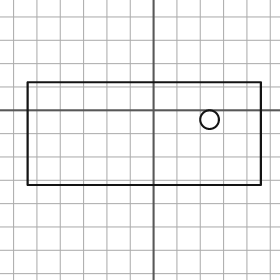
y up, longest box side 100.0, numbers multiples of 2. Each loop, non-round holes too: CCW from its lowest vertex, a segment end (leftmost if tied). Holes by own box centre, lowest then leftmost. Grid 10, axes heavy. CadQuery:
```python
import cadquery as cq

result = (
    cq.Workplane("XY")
    .moveTo(-54.0, -32.0)
    .lineTo(46.0, -32.0)
    .lineTo(46.0, 12.0)
    .lineTo(-54.0, 12.0)
    .close()
    .moveTo(24.0, -4.0)
    .circle(4.0)
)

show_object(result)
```